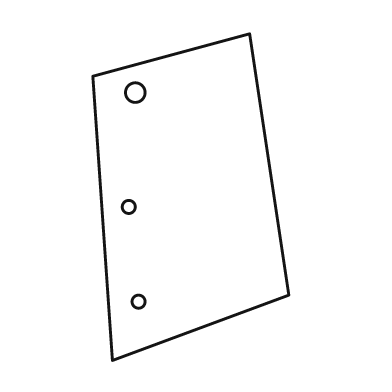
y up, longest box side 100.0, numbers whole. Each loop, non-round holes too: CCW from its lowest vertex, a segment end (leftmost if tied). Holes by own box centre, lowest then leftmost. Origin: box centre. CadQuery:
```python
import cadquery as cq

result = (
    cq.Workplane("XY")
    .moveTo(-24.0, -50.0)
    .lineTo(30.0, -30.0)
    .lineTo(18.0, 50.0)
    .lineTo(-30.0, 37.0)
    .close()
    .moveTo(-16.0, -32.0)
    .circle(2.0)
    .moveTo(-19.0, -3.0)
    .circle(2.0)
    .moveTo(-17.0, 32.0)
    .circle(3.0)
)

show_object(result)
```